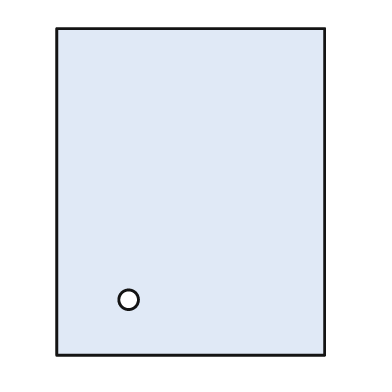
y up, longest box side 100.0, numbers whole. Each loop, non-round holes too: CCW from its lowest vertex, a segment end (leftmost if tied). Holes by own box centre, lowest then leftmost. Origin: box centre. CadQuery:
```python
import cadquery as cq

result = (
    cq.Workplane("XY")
    .moveTo(-41.0, -50.0)
    .lineTo(41.0, -50.0)
    .lineTo(41.0, 50.0)
    .lineTo(-41.0, 50.0)
    .close()
    .moveTo(-19.0, -33.0)
    .circle(3.0)
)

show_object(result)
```